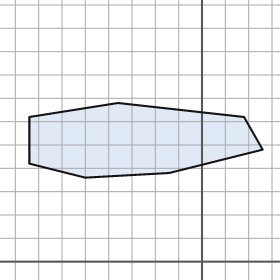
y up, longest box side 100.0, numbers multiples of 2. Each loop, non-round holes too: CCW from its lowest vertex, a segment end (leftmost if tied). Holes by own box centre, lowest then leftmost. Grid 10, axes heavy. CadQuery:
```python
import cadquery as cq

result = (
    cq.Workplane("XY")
    .moveTo(-50.0, 36.0)
    .lineTo(-14.0, 38.0)
    .lineTo(26.0, 48.0)
    .lineTo(18.0, 62.0)
    .lineTo(-36.0, 68.0)
    .lineTo(-74.0, 62.0)
    .lineTo(-74.0, 42.0)
    .close()
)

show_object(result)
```